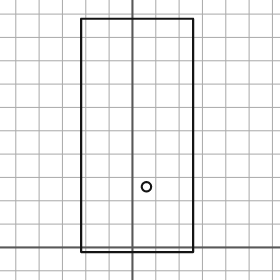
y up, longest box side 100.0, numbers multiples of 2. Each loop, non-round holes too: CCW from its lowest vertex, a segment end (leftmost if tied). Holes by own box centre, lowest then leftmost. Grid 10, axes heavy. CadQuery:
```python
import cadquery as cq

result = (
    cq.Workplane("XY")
    .moveTo(-22.0, -2.0)
    .lineTo(26.0, -2.0)
    .lineTo(26.0, 98.0)
    .lineTo(-22.0, 98.0)
    .close()
    .moveTo(6.0, 26.0)
    .circle(2.0)
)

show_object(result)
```